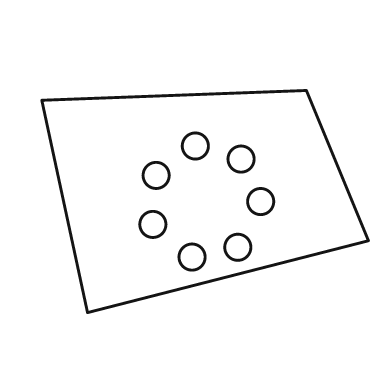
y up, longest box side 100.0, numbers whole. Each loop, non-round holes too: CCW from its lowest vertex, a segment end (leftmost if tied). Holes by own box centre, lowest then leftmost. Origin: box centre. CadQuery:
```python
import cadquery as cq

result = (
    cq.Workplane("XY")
    .moveTo(-36.0, -34.0)
    .lineTo(50.0, -12.0)
    .lineTo(31.0, 34.0)
    .lineTo(-50.0, 31.0)
    .close()
    .moveTo(-4.0, -17.0)
    .circle(4.0)
    .moveTo(10.0, -14.0)
    .circle(4.0)
    .moveTo(-16.0, -7.0)
    .circle(4.0)
    .moveTo(17.0, 0.0)
    .circle(4.0)
    .moveTo(-15.0, 8.0)
    .circle(4.0)
    .moveTo(11.0, 13.0)
    .circle(4.0)
    .moveTo(-3.0, 17.0)
    .circle(4.0)
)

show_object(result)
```